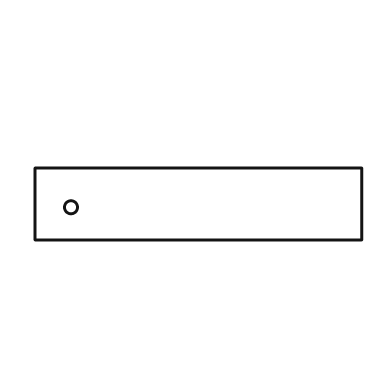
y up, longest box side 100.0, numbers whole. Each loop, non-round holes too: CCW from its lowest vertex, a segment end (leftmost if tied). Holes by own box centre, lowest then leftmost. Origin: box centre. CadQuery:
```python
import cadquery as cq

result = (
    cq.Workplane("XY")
    .moveTo(-50.0, -11.0)
    .lineTo(50.0, -11.0)
    .lineTo(50.0, 11.0)
    .lineTo(-50.0, 11.0)
    .close()
    .moveTo(-39.0, -1.0)
    .circle(2.0)
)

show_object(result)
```